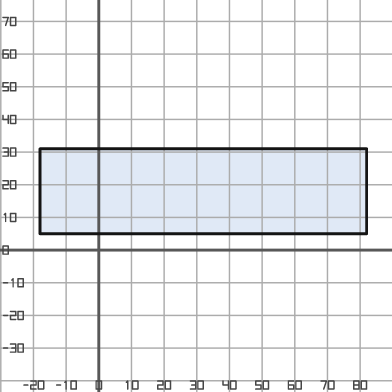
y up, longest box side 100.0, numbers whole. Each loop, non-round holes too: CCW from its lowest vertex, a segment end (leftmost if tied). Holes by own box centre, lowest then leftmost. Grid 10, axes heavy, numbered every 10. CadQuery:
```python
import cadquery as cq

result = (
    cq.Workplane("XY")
    .moveTo(-18.0, 5.0)
    .lineTo(82.0, 5.0)
    .lineTo(82.0, 31.0)
    .lineTo(-18.0, 31.0)
    .close()
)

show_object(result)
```